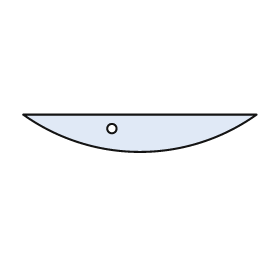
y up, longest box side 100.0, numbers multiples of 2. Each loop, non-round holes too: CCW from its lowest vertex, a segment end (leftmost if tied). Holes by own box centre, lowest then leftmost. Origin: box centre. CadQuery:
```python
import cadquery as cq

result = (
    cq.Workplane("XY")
    .moveTo(-50.0, 8.0)
    .threePointArc((0.0, -8.0), (50.0, 8.0))
    .close()
    .moveTo(-12.0, 2.0)
    .circle(2.0)
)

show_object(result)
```